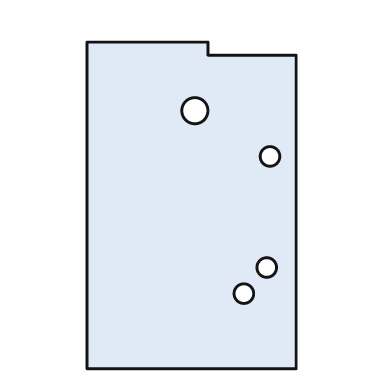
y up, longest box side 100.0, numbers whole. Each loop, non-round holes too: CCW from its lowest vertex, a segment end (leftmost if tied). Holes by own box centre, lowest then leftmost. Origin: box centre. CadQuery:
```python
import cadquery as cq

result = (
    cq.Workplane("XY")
    .moveTo(-32.0, -50.0)
    .lineTo(32.0, -50.0)
    .lineTo(32.0, 46.0)
    .lineTo(5.0, 46.0)
    .lineTo(5.0, 50.0)
    .lineTo(-32.0, 50.0)
    .close()
    .moveTo(16.0, -27.0)
    .circle(3.0)
    .moveTo(23.0, -19.0)
    .circle(3.0)
    .moveTo(24.0, 15.0)
    .circle(3.0)
    .moveTo(1.0, 29.0)
    .circle(4.0)
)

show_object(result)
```